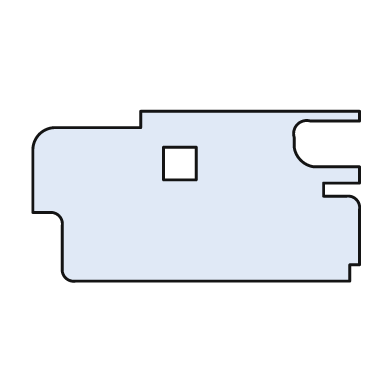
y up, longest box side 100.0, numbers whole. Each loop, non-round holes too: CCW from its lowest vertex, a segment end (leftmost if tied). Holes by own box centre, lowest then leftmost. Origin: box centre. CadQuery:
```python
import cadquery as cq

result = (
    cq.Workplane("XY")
    .moveTo(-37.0, -26.0)
    .lineTo(47.0, -26.0)
    .lineTo(47.0, -21.0)
    .lineTo(50.0, -21.0)
    .lineTo(50.0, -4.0)
    .threePointArc((49.0, -1.0), (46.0, 0.0))
    .lineTo(39.0, 0.0)
    .lineTo(39.0, 4.0)
    .lineTo(50.0, 4.0)
    .lineTo(50.0, 9.0)
    .lineTo(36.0, 9.0)
    .threePointArc((32.0, 11.0), (30.0, 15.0))
    .lineTo(30.0, 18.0)
    .threePointArc((31.0, 22.0), (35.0, 23.0))
    .lineTo(50.0, 23.0)
    .lineTo(50.0, 26.0)
    .lineTo(-17.0, 26.0)
    .lineTo(-17.0, 21.0)
    .lineTo(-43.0, 21.0)
    .threePointArc((-48.0, 19.0), (-50.0, 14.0))
    .lineTo(-50.0, -5.0)
    .lineTo(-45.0, -5.0)
    .threePointArc((-42.0, -6.0), (-41.0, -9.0))
    .lineTo(-41.0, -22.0)
    .threePointArc((-40.0, -25.0), (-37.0, -26.0))
    .close()
    .moveTo(-10.0, 5.0)
    .lineTo(0.0, 5.0)
    .lineTo(0.0, 15.0)
    .lineTo(-10.0, 15.0)
    .close()
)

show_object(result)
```